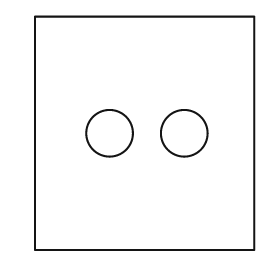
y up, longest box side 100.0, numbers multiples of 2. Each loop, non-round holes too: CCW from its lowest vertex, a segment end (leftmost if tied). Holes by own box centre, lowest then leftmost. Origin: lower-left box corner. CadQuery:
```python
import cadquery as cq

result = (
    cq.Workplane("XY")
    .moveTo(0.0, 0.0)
    .lineTo(94.0, 0.0)
    .lineTo(94.0, 100.0)
    .lineTo(0.0, 100.0)
    .close()
    .moveTo(32.0, 50.0)
    .circle(10.0)
    .moveTo(64.0, 50.0)
    .circle(10.0)
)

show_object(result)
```